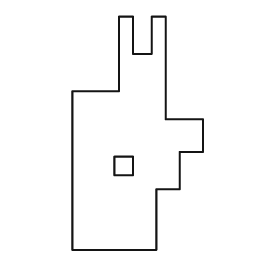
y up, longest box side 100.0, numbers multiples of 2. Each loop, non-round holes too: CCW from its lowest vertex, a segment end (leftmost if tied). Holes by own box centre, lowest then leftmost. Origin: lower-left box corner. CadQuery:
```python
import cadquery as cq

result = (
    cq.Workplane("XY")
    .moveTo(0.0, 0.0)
    .lineTo(36.0, 0.0)
    .lineTo(36.0, 26.0)
    .lineTo(46.0, 26.0)
    .lineTo(46.0, 42.0)
    .lineTo(56.0, 42.0)
    .lineTo(56.0, 56.0)
    .lineTo(40.0, 56.0)
    .lineTo(40.0, 100.0)
    .lineTo(34.0, 100.0)
    .lineTo(34.0, 84.0)
    .lineTo(26.0, 84.0)
    .lineTo(26.0, 100.0)
    .lineTo(20.0, 100.0)
    .lineTo(20.0, 68.0)
    .lineTo(0.0, 68.0)
    .close()
    .moveTo(18.0, 32.0)
    .lineTo(26.0, 32.0)
    .lineTo(26.0, 40.0)
    .lineTo(18.0, 40.0)
    .close()
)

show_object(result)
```